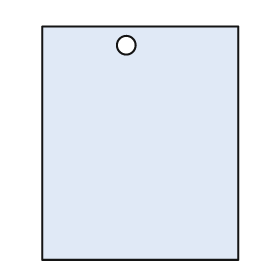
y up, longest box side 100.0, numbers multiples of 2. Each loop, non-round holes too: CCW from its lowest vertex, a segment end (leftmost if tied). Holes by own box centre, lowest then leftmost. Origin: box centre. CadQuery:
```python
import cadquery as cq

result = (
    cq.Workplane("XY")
    .moveTo(-42.0, -50.0)
    .lineTo(42.0, -50.0)
    .lineTo(42.0, 50.0)
    .lineTo(-42.0, 50.0)
    .close()
    .moveTo(-6.0, 42.0)
    .circle(4.0)
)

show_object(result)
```